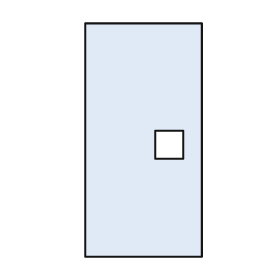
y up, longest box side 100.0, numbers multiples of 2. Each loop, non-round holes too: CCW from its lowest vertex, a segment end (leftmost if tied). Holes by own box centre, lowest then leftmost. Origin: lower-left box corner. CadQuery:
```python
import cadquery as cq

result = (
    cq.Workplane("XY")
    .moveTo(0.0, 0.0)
    .lineTo(50.0, 0.0)
    .lineTo(50.0, 100.0)
    .lineTo(0.0, 100.0)
    .close()
    .moveTo(30.0, 42.0)
    .lineTo(42.0, 42.0)
    .lineTo(42.0, 54.0)
    .lineTo(30.0, 54.0)
    .close()
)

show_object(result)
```